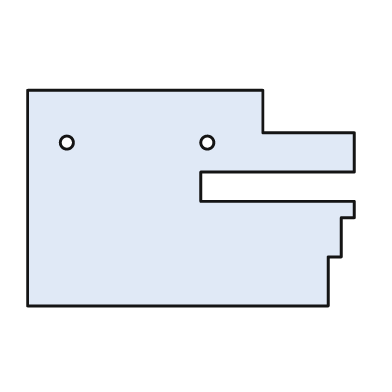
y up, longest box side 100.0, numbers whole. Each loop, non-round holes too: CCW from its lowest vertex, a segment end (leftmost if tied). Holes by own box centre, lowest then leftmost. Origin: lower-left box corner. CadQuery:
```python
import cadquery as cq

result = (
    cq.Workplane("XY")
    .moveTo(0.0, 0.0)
    .lineTo(92.0, 0.0)
    .lineTo(92.0, 15.0)
    .lineTo(96.0, 15.0)
    .lineTo(96.0, 27.0)
    .lineTo(100.0, 27.0)
    .lineTo(100.0, 32.0)
    .lineTo(53.0, 32.0)
    .lineTo(53.0, 41.0)
    .lineTo(100.0, 41.0)
    .lineTo(100.0, 53.0)
    .lineTo(72.0, 53.0)
    .lineTo(72.0, 66.0)
    .lineTo(0.0, 66.0)
    .close()
    .moveTo(12.0, 50.0)
    .circle(2.0)
    .moveTo(55.0, 50.0)
    .circle(2.0)
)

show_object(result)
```